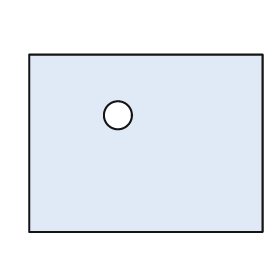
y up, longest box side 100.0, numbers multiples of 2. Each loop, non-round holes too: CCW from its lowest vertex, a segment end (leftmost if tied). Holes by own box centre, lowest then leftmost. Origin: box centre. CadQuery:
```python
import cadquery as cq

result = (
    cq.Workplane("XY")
    .moveTo(-50.0, -38.0)
    .lineTo(50.0, -38.0)
    .lineTo(50.0, 38.0)
    .lineTo(-50.0, 38.0)
    .close()
    .moveTo(-12.0, 12.0)
    .circle(6.0)
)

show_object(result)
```